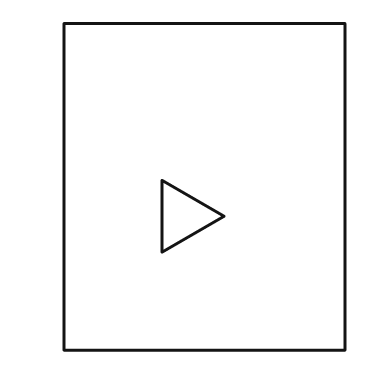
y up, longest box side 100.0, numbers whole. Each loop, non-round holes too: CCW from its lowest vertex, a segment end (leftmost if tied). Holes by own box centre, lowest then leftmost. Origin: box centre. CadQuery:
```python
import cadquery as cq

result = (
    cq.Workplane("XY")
    .moveTo(-43.0, -50.0)
    .lineTo(43.0, -50.0)
    .lineTo(43.0, 50.0)
    .lineTo(-43.0, 50.0)
    .close()
    .moveTo(-13.0, -20.0)
    .lineTo(6.0, -9.0)
    .lineTo(-13.0, 2.0)
    .close()
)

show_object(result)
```